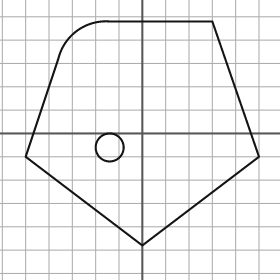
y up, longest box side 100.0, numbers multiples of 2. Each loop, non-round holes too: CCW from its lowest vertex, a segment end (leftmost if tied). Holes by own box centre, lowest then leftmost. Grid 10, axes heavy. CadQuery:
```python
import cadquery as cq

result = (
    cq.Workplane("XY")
    .moveTo(0.0, -48.0)
    .lineTo(50.0, -10.0)
    .lineTo(30.0, 48.0)
    .lineTo(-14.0, 48.0)
    .threePointArc((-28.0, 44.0), (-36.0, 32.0))
    .lineTo(-50.0, -10.0)
    .close()
    .moveTo(-14.0, -6.0)
    .circle(6.0)
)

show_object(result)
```